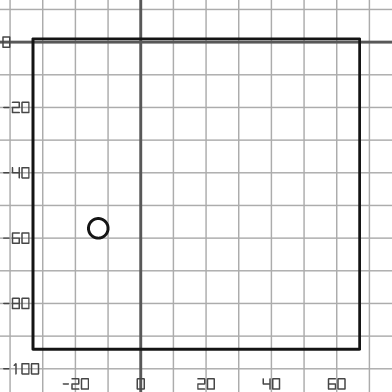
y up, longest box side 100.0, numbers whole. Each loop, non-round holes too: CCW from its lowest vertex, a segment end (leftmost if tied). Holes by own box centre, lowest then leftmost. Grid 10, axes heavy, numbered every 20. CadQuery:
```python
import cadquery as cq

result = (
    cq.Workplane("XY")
    .moveTo(-33.0, -94.0)
    .lineTo(67.0, -94.0)
    .lineTo(67.0, 1.0)
    .lineTo(-33.0, 1.0)
    .close()
    .moveTo(-13.0, -57.0)
    .circle(3.0)
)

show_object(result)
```